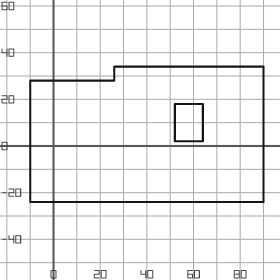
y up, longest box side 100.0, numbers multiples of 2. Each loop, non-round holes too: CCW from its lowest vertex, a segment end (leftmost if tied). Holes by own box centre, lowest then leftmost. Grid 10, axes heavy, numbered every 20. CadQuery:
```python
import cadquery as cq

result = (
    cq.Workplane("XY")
    .moveTo(-10.0, -24.0)
    .lineTo(90.0, -24.0)
    .lineTo(90.0, 34.0)
    .lineTo(26.0, 34.0)
    .lineTo(26.0, 28.0)
    .lineTo(-10.0, 28.0)
    .close()
    .moveTo(52.0, 2.0)
    .lineTo(64.0, 2.0)
    .lineTo(64.0, 18.0)
    .lineTo(52.0, 18.0)
    .close()
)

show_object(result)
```